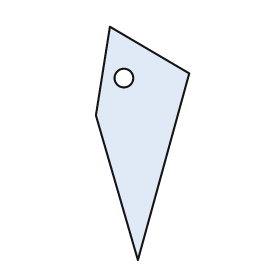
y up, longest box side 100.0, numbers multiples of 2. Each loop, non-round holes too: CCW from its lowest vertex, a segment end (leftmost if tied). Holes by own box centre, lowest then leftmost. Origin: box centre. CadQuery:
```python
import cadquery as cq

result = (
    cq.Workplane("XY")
    .moveTo(-2.0, -50.0)
    .lineTo(20.0, 30.0)
    .lineTo(-14.0, 50.0)
    .lineTo(-20.0, 12.0)
    .close()
    .moveTo(-8.0, 28.0)
    .circle(4.0)
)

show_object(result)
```